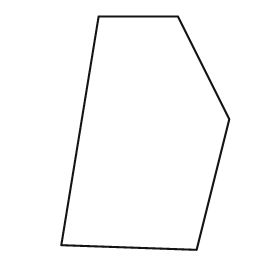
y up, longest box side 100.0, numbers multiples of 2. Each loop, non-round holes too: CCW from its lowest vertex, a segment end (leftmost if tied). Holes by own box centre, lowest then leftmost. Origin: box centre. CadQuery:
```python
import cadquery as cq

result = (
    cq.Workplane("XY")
    .moveTo(22.0, -50.0)
    .lineTo(36.0, 6.0)
    .lineTo(14.0, 50.0)
    .lineTo(-20.0, 50.0)
    .lineTo(-36.0, -48.0)
    .close()
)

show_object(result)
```